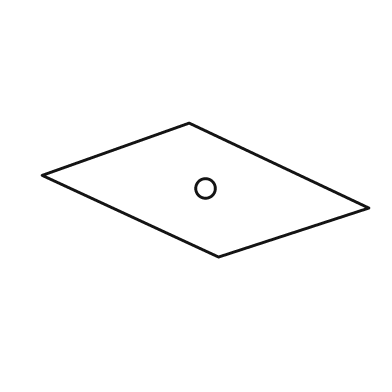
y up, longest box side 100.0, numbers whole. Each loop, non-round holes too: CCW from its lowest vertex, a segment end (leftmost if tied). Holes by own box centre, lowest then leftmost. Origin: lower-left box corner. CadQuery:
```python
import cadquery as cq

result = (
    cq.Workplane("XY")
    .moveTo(54.0, 0.0)
    .lineTo(100.0, 15.0)
    .lineTo(45.0, 41.0)
    .lineTo(0.0, 25.0)
    .close()
    .moveTo(50.0, 21.0)
    .circle(3.0)
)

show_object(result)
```